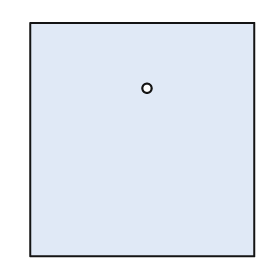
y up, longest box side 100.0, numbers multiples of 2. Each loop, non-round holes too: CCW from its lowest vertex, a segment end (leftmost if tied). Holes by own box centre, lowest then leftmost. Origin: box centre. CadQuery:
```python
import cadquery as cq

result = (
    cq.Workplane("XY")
    .moveTo(-48.0, -50.0)
    .lineTo(48.0, -50.0)
    .lineTo(48.0, 50.0)
    .lineTo(-48.0, 50.0)
    .close()
    .moveTo(2.0, 22.0)
    .circle(2.0)
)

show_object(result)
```